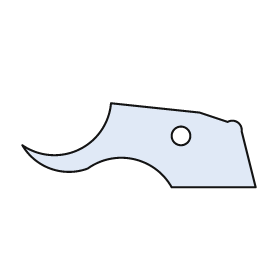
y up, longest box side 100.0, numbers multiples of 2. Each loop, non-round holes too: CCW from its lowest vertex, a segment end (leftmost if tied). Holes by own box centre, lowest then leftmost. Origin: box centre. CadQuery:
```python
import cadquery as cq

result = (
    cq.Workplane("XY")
    .moveTo(14.0, -18.0)
    .lineTo(50.0, -18.0)
    .lineTo(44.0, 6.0)
    .threePointArc((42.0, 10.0), (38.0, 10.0))
    .lineTo(26.0, 14.0)
    .lineTo(-12.0, 18.0)
    .threePointArc((-26.0, -2.0), (-50.0, 0.0))
    .threePointArc((-38.0, -10.0), (-22.0, -10.0))
    .threePointArc((-2.0, -6.0), (14.0, -18.0))
    .close()
    .moveTo(18.0, 4.0)
    .circle(4.0)
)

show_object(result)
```